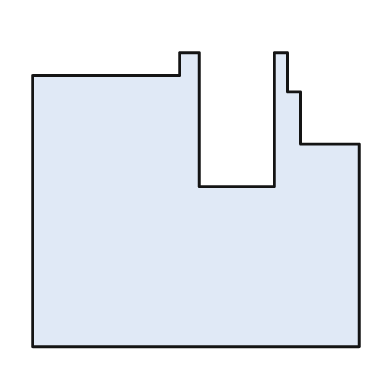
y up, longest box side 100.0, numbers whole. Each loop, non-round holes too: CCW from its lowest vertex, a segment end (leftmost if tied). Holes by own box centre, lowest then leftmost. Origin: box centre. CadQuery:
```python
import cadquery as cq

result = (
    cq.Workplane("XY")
    .moveTo(-50.0, -45.0)
    .lineTo(50.0, -45.0)
    .lineTo(50.0, 17.0)
    .lineTo(32.0, 17.0)
    .lineTo(32.0, 33.0)
    .lineTo(28.0, 33.0)
    .lineTo(28.0, 45.0)
    .lineTo(24.0, 45.0)
    .lineTo(24.0, 4.0)
    .lineTo(1.0, 4.0)
    .lineTo(1.0, 45.0)
    .lineTo(-5.0, 45.0)
    .lineTo(-5.0, 38.0)
    .lineTo(-50.0, 38.0)
    .close()
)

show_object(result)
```